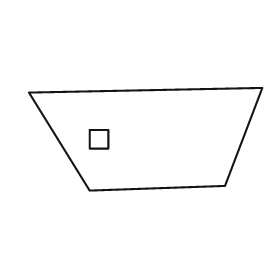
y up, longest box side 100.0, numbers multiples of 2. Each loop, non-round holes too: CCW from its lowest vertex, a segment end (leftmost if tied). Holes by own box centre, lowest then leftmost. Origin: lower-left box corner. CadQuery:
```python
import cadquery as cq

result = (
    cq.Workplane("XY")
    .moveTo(26.0, 0.0)
    .lineTo(84.0, 2.0)
    .lineTo(100.0, 44.0)
    .lineTo(0.0, 42.0)
    .close()
    .moveTo(26.0, 18.0)
    .lineTo(34.0, 18.0)
    .lineTo(34.0, 26.0)
    .lineTo(26.0, 26.0)
    .close()
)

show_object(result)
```